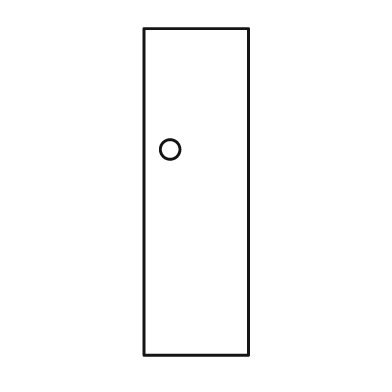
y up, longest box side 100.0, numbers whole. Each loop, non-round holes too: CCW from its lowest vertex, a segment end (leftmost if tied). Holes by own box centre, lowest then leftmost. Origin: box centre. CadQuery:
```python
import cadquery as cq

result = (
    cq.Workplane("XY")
    .moveTo(-16.0, -50.0)
    .lineTo(16.0, -50.0)
    .lineTo(16.0, 50.0)
    .lineTo(-16.0, 50.0)
    .close()
    .moveTo(-8.0, 13.0)
    .circle(3.0)
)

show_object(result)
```